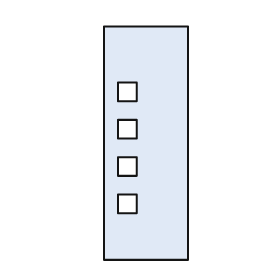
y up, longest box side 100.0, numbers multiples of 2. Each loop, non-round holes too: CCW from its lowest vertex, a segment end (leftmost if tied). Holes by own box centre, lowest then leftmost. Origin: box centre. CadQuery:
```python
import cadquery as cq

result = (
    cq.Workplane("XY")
    .moveTo(-18.0, -50.0)
    .lineTo(18.0, -50.0)
    .lineTo(18.0, 50.0)
    .lineTo(-18.0, 50.0)
    .close()
    .moveTo(-12.0, -30.0)
    .lineTo(-4.0, -30.0)
    .lineTo(-4.0, -22.0)
    .lineTo(-12.0, -22.0)
    .close()
    .moveTo(-12.0, -14.0)
    .lineTo(-4.0, -14.0)
    .lineTo(-4.0, -6.0)
    .lineTo(-12.0, -6.0)
    .close()
    .moveTo(-12.0, 2.0)
    .lineTo(-4.0, 2.0)
    .lineTo(-4.0, 10.0)
    .lineTo(-12.0, 10.0)
    .close()
    .moveTo(-12.0, 18.0)
    .lineTo(-4.0, 18.0)
    .lineTo(-4.0, 26.0)
    .lineTo(-12.0, 26.0)
    .close()
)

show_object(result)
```